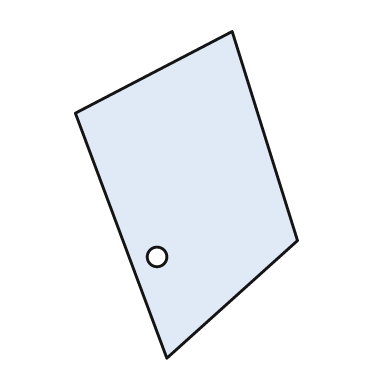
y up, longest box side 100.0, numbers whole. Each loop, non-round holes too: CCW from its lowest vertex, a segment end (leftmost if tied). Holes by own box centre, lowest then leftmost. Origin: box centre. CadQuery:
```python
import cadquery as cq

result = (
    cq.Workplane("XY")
    .moveTo(-6.0, -50.0)
    .lineTo(34.0, -14.0)
    .lineTo(14.0, 50.0)
    .lineTo(-34.0, 25.0)
    .close()
    .moveTo(-9.0, -19.0)
    .circle(3.0)
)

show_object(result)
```